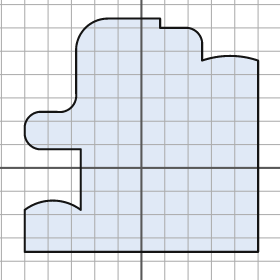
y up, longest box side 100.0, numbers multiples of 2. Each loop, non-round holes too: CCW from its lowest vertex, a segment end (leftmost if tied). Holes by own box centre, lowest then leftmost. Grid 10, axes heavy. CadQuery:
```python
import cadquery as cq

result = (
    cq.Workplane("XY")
    .moveTo(-50.0, -36.0)
    .lineTo(50.0, -36.0)
    .lineTo(50.0, 46.0)
    .threePointArc((38.0, 48.0), (26.0, 46.0))
    .lineTo(26.0, 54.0)
    .threePointArc((24.0, 58.0), (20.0, 60.0))
    .lineTo(8.0, 60.0)
    .lineTo(8.0, 64.0)
    .lineTo(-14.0, 64.0)
    .threePointArc((-24.0, 60.0), (-28.0, 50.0))
    .lineTo(-28.0, 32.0)
    .threePointArc((-30.0, 26.0), (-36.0, 24.0))
    .lineTo(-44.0, 24.0)
    .threePointArc((-48.0, 22.0), (-50.0, 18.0))
    .lineTo(-50.0, 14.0)
    .threePointArc((-48.0, 10.0), (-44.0, 8.0))
    .lineTo(-26.0, 8.0)
    .lineTo(-26.0, -18.0)
    .threePointArc((-38.0, -14.0), (-50.0, -18.0))
    .close()
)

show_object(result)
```